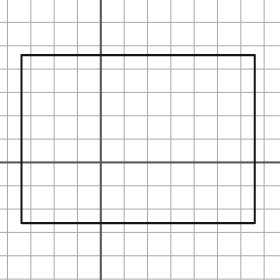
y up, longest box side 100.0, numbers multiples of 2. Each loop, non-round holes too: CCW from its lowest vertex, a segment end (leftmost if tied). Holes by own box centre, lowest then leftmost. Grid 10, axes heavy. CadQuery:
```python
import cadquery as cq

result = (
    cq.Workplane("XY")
    .moveTo(-34.0, -26.0)
    .lineTo(66.0, -26.0)
    .lineTo(66.0, 46.0)
    .lineTo(-34.0, 46.0)
    .close()
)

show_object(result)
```